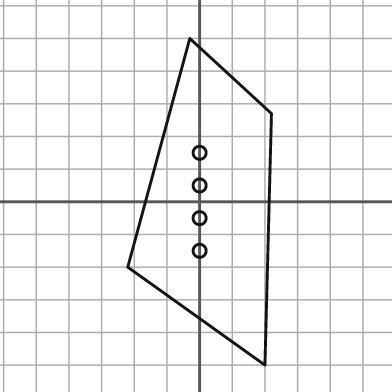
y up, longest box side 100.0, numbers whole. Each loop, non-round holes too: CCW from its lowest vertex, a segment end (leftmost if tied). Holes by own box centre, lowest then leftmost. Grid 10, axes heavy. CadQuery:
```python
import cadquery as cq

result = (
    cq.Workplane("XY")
    .moveTo(20.0, -50.0)
    .lineTo(22.0, 27.0)
    .lineTo(-3.0, 50.0)
    .lineTo(-22.0, -20.0)
    .close()
    .moveTo(0.0, -15.0)
    .circle(2.0)
    .moveTo(0.0, -5.0)
    .circle(2.0)
    .moveTo(0.0, 5.0)
    .circle(2.0)
    .moveTo(0.0, 15.0)
    .circle(2.0)
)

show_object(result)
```